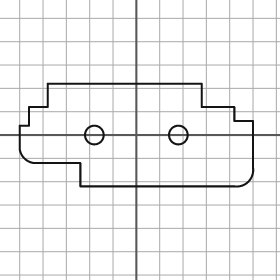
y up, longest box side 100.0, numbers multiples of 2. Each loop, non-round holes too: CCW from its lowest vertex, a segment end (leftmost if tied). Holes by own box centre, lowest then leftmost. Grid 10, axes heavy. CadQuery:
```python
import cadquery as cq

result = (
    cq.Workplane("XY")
    .moveTo(-24.0, -22.0)
    .lineTo(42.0, -22.0)
    .threePointArc((48.0, -20.0), (50.0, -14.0))
    .lineTo(50.0, 6.0)
    .lineTo(42.0, 6.0)
    .lineTo(42.0, 12.0)
    .lineTo(28.0, 12.0)
    .lineTo(28.0, 22.0)
    .lineTo(-38.0, 22.0)
    .lineTo(-38.0, 12.0)
    .lineTo(-46.0, 12.0)
    .lineTo(-46.0, 4.0)
    .lineTo(-50.0, 4.0)
    .lineTo(-50.0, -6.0)
    .threePointArc((-48.0, -10.0), (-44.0, -12.0))
    .lineTo(-24.0, -12.0)
    .close()
    .moveTo(-18.0, 0.0)
    .circle(4.0)
    .moveTo(18.0, 0.0)
    .circle(4.0)
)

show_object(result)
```